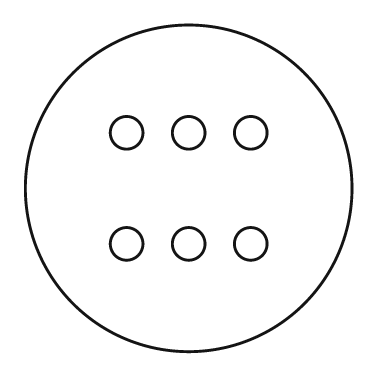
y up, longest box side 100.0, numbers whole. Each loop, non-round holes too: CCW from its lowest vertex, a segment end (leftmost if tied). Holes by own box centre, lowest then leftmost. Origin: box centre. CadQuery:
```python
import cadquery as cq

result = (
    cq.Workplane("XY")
    .moveTo(0.0, 0.0)
    .circle(50.0)
    .moveTo(-19.0, -17.0)
    .circle(5.0)
    .moveTo(0.0, -17.0)
    .circle(5.0)
    .moveTo(19.0, -17.0)
    .circle(5.0)
    .moveTo(-19.0, 17.0)
    .circle(5.0)
    .moveTo(0.0, 17.0)
    .circle(5.0)
    .moveTo(19.0, 17.0)
    .circle(5.0)
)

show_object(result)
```